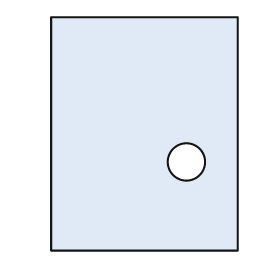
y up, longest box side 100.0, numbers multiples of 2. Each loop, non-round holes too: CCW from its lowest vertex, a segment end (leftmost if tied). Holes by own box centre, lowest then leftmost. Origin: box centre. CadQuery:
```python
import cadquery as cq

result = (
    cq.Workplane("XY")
    .moveTo(-40.0, -50.0)
    .lineTo(40.0, -50.0)
    .lineTo(40.0, 50.0)
    .lineTo(-40.0, 50.0)
    .close()
    .moveTo(18.0, -12.0)
    .circle(8.0)
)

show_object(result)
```